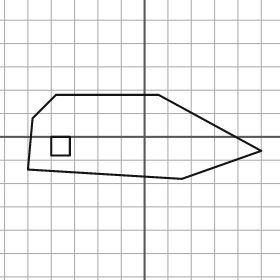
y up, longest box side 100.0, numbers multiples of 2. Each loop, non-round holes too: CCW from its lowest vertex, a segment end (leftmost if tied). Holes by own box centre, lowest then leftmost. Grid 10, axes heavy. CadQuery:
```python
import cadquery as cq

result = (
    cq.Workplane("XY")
    .moveTo(16.0, -18.0)
    .lineTo(50.0, -6.0)
    .lineTo(6.0, 18.0)
    .lineTo(-38.0, 18.0)
    .lineTo(-48.0, 8.0)
    .lineTo(-50.0, -14.0)
    .close()
    .moveTo(-40.0, -8.0)
    .lineTo(-32.0, -8.0)
    .lineTo(-32.0, 0.0)
    .lineTo(-40.0, 0.0)
    .close()
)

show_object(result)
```